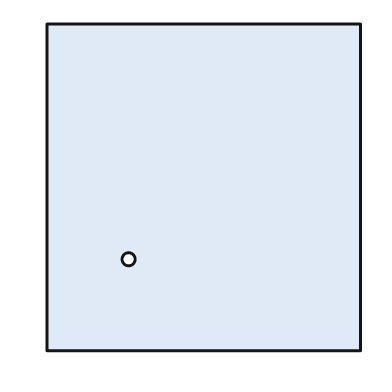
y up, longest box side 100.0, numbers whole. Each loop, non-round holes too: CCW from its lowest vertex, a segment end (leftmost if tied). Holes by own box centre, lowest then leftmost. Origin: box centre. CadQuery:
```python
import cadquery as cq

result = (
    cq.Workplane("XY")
    .moveTo(-48.0, -50.0)
    .lineTo(48.0, -50.0)
    .lineTo(48.0, 50.0)
    .lineTo(-48.0, 50.0)
    .close()
    .moveTo(-23.0, -22.0)
    .circle(2.0)
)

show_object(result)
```